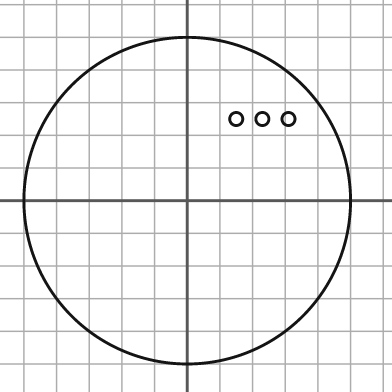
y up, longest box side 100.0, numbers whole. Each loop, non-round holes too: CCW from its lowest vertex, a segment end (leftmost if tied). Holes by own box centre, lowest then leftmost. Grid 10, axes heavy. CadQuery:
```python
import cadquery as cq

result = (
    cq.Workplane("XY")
    .moveTo(0.0, 0.0)
    .circle(50.0)
    .moveTo(15.0, 25.0)
    .circle(2.0)
    .moveTo(23.0, 25.0)
    .circle(2.0)
    .moveTo(31.0, 25.0)
    .circle(2.0)
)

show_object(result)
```